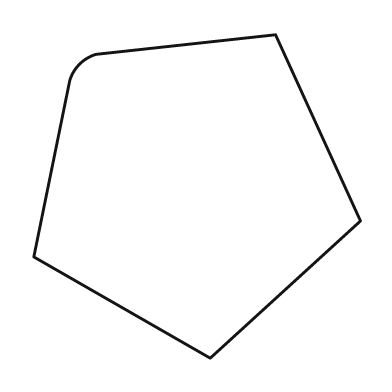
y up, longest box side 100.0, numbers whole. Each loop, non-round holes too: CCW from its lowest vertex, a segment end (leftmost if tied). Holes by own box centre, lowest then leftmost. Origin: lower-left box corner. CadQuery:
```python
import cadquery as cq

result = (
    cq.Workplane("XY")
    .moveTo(54.0, 0.0)
    .lineTo(100.0, 42.0)
    .lineTo(74.0, 99.0)
    .lineTo(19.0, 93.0)
    .threePointArc((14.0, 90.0), (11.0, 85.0))
    .lineTo(0.0, 31.0)
    .close()
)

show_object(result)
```